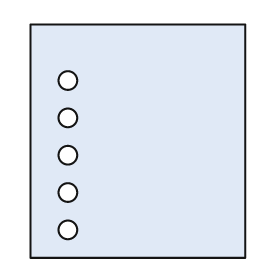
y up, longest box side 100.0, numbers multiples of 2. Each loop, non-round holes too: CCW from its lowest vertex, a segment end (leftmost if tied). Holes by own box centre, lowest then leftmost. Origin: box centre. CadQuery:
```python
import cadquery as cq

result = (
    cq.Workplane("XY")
    .moveTo(-46.0, -50.0)
    .lineTo(46.0, -50.0)
    .lineTo(46.0, 50.0)
    .lineTo(-46.0, 50.0)
    .close()
    .moveTo(-30.0, -38.0)
    .circle(4.0)
    .moveTo(-30.0, -22.0)
    .circle(4.0)
    .moveTo(-30.0, -6.0)
    .circle(4.0)
    .moveTo(-30.0, 10.0)
    .circle(4.0)
    .moveTo(-30.0, 26.0)
    .circle(4.0)
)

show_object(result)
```